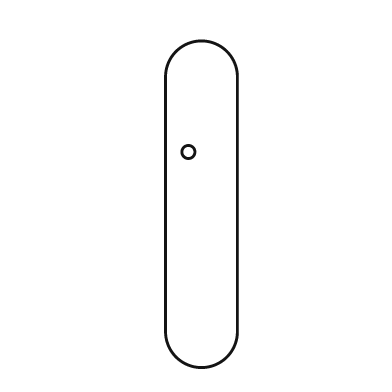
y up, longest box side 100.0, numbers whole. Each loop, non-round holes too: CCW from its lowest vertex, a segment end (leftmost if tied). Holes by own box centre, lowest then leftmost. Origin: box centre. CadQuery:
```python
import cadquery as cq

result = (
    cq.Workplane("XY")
    .moveTo(-11.0, -39.0)
    .threePointArc((0.0, -50.0), (11.0, -39.0))
    .lineTo(11.0, 39.0)
    .threePointArc((0.0, 50.0), (-11.0, 39.0))
    .close()
    .moveTo(-4.0, 16.0)
    .circle(2.0)
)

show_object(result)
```